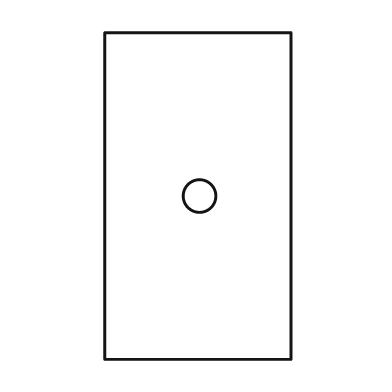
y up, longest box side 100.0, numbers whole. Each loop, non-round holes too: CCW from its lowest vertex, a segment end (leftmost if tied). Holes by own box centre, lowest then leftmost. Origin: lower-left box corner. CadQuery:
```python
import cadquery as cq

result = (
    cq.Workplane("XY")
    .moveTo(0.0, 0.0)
    .lineTo(57.0, 0.0)
    .lineTo(57.0, 100.0)
    .lineTo(0.0, 100.0)
    .close()
    .moveTo(29.0, 50.0)
    .circle(5.0)
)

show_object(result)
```